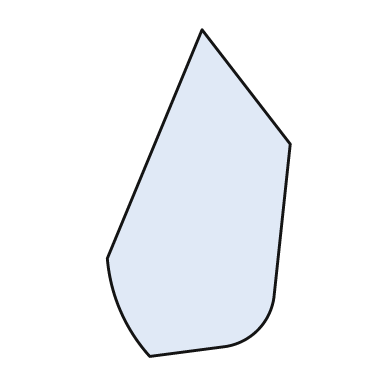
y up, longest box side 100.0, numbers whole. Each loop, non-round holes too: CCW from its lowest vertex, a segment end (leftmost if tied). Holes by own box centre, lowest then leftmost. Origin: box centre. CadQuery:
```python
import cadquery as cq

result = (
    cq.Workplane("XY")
    .moveTo(-15.0, -50.0)
    .lineTo(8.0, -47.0)
    .threePointArc((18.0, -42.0), (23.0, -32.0))
    .lineTo(28.0, 15.0)
    .lineTo(1.0, 50.0)
    .lineTo(-28.0, -20.0)
    .threePointArc((-24.0, -36.0), (-15.0, -50.0))
    .close()
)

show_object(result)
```